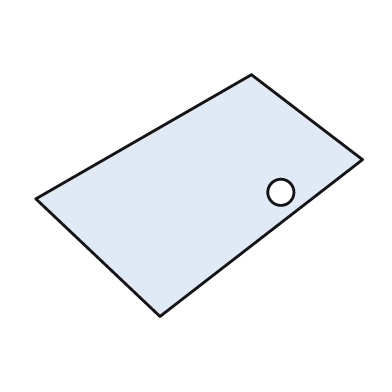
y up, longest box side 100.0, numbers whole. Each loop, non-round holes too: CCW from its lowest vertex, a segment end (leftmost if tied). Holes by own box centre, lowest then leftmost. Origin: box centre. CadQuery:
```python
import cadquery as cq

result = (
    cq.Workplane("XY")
    .moveTo(-12.0, -37.0)
    .lineTo(50.0, 11.0)
    .lineTo(16.0, 37.0)
    .lineTo(-50.0, -1.0)
    .close()
    .moveTo(25.0, 1.0)
    .circle(4.0)
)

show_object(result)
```